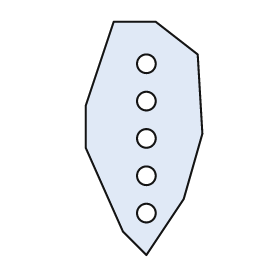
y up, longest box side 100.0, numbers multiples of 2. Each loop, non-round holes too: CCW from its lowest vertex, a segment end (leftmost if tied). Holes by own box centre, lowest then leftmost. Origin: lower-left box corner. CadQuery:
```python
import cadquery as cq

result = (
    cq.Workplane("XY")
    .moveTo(26.0, 0.0)
    .lineTo(42.0, 24.0)
    .lineTo(50.0, 52.0)
    .lineTo(48.0, 86.0)
    .lineTo(30.0, 100.0)
    .lineTo(12.0, 100.0)
    .lineTo(0.0, 64.0)
    .lineTo(0.0, 46.0)
    .lineTo(16.0, 10.0)
    .close()
    .moveTo(26.0, 18.0)
    .circle(4.0)
    .moveTo(26.0, 34.0)
    .circle(4.0)
    .moveTo(26.0, 50.0)
    .circle(4.0)
    .moveTo(26.0, 66.0)
    .circle(4.0)
    .moveTo(26.0, 82.0)
    .circle(4.0)
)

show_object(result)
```